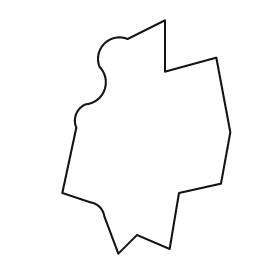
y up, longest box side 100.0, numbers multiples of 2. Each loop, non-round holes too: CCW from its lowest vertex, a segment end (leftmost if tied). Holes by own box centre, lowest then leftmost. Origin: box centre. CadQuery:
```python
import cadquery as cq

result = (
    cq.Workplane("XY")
    .moveTo(-12.0, -50.0)
    .lineTo(-4.0, -42.0)
    .lineTo(10.0, -48.0)
    .lineTo(14.0, -24.0)
    .lineTo(32.0, -20.0)
    .lineTo(36.0, 2.0)
    .lineTo(30.0, 34.0)
    .lineTo(8.0, 28.0)
    .lineTo(8.0, 50.0)
    .lineTo(-8.0, 42.0)
    .threePointArc((-18.0, 40.0), (-20.0, 30.0))
    .threePointArc((-18.0, 20.0), (-26.0, 14.0))
    .threePointArc((-30.0, 10.0), (-30.0, 4.0))
    .lineTo(-36.0, -24.0)
    .lineTo(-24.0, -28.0)
    .threePointArc((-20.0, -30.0), (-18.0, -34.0))
    .close()
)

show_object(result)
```